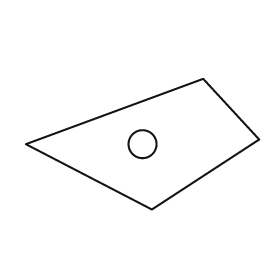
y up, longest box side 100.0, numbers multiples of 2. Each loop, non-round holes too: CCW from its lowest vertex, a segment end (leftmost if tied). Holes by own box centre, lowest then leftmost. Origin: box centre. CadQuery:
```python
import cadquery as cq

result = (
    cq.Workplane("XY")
    .moveTo(4.0, -28.0)
    .lineTo(50.0, 2.0)
    .lineTo(26.0, 28.0)
    .lineTo(-50.0, 0.0)
    .close()
    .moveTo(0.0, 0.0)
    .circle(6.0)
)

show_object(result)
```